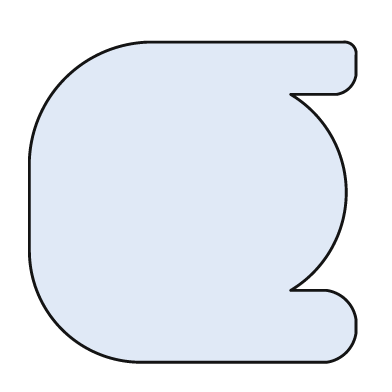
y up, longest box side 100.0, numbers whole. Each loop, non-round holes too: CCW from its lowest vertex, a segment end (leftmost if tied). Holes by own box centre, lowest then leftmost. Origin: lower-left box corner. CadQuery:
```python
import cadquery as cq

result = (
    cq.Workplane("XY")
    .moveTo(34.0, 0.0)
    .lineTo(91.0, 0.0)
    .threePointArc((97.0, 3.0), (100.0, 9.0))
    .lineTo(100.0, 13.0)
    .threePointArc((97.0, 19.0), (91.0, 22.0))
    .lineTo(80.0, 22.0)
    .threePointArc((97.0, 52.0), (80.0, 82.0))
    .lineTo(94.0, 82.0)
    .threePointArc((98.0, 84.0), (100.0, 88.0))
    .lineTo(100.0, 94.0)
    .threePointArc((99.0, 97.0), (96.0, 98.0))
    .lineTo(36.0, 98.0)
    .threePointArc((11.0, 87.0), (0.0, 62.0))
    .lineTo(0.0, 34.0)
    .threePointArc((10.0, 10.0), (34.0, 0.0))
    .close()
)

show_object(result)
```